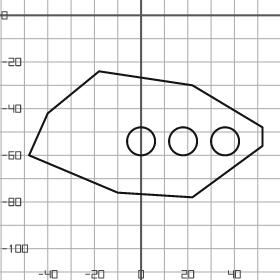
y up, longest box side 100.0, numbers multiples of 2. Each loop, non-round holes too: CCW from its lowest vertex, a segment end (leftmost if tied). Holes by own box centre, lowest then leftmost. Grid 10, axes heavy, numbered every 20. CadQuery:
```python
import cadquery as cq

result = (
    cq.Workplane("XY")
    .moveTo(22.0, -78.0)
    .lineTo(52.0, -56.0)
    .lineTo(52.0, -48.0)
    .lineTo(22.0, -30.0)
    .lineTo(-18.0, -24.0)
    .lineTo(-40.0, -42.0)
    .lineTo(-48.0, -60.0)
    .lineTo(-10.0, -76.0)
    .close()
    .moveTo(0.0, -54.0)
    .circle(6.0)
    .moveTo(18.0, -54.0)
    .circle(6.0)
    .moveTo(36.0, -54.0)
    .circle(6.0)
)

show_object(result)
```